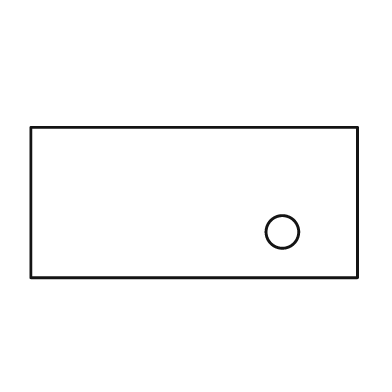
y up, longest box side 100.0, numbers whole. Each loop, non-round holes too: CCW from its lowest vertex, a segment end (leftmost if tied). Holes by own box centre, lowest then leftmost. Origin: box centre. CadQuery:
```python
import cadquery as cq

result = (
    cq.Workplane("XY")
    .moveTo(-50.0, -23.0)
    .lineTo(50.0, -23.0)
    .lineTo(50.0, 23.0)
    .lineTo(-50.0, 23.0)
    .close()
    .moveTo(27.0, -9.0)
    .circle(5.0)
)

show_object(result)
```